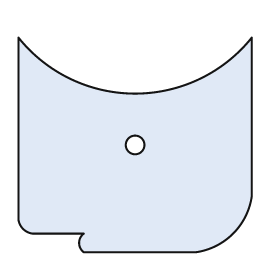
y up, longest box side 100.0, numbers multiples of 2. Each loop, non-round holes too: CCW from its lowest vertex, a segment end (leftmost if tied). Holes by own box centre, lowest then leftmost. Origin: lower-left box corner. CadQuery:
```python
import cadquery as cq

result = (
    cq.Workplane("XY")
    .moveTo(28.0, 0.0)
    .lineTo(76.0, 0.0)
    .threePointArc((92.0, 8.0), (100.0, 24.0))
    .lineTo(100.0, 92.0)
    .threePointArc((50.0, 68.0), (0.0, 92.0))
    .lineTo(0.0, 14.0)
    .threePointArc((2.0, 10.0), (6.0, 8.0))
    .lineTo(28.0, 8.0)
    .threePointArc((26.0, 4.0), (28.0, 0.0))
    .close()
    .moveTo(50.0, 46.0)
    .circle(4.0)
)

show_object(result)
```